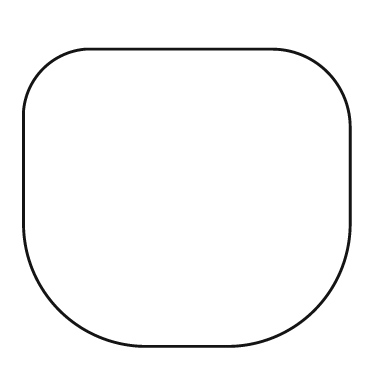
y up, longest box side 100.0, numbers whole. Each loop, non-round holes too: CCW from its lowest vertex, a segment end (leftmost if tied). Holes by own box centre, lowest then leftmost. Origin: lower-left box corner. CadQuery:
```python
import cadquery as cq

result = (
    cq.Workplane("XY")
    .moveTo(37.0, 0.0)
    .lineTo(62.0, 0.0)
    .threePointArc((89.0, 11.0), (100.0, 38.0))
    .lineTo(100.0, 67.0)
    .threePointArc((93.0, 84.0), (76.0, 91.0))
    .lineTo(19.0, 91.0)
    .threePointArc((6.0, 85.0), (0.0, 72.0))
    .lineTo(0.0, 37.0)
    .threePointArc((11.0, 11.0), (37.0, 0.0))
    .close()
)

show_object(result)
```